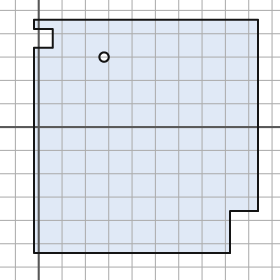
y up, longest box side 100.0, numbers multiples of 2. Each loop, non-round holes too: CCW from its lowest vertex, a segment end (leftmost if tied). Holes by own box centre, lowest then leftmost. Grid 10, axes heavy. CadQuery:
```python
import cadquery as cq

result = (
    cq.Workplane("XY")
    .moveTo(-2.0, -54.0)
    .lineTo(82.0, -54.0)
    .lineTo(82.0, -36.0)
    .lineTo(94.0, -36.0)
    .lineTo(94.0, 46.0)
    .lineTo(-2.0, 46.0)
    .lineTo(-2.0, 42.0)
    .lineTo(6.0, 42.0)
    .lineTo(6.0, 34.0)
    .lineTo(-2.0, 34.0)
    .close()
    .moveTo(28.0, 30.0)
    .circle(2.0)
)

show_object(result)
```